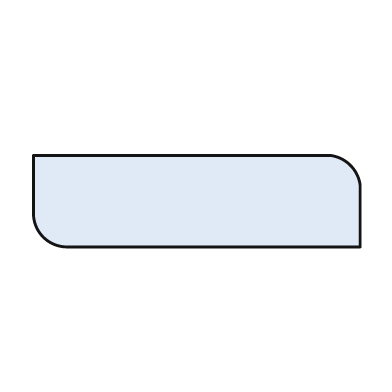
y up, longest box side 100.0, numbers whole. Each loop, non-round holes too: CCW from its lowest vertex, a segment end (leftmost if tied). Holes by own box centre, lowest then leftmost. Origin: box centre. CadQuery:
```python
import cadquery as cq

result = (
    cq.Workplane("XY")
    .moveTo(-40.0, -14.0)
    .lineTo(50.0, -14.0)
    .lineTo(50.0, 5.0)
    .threePointArc((47.0, 11.0), (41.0, 14.0))
    .lineTo(-50.0, 14.0)
    .lineTo(-50.0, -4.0)
    .threePointArc((-47.0, -11.0), (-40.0, -14.0))
    .close()
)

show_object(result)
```